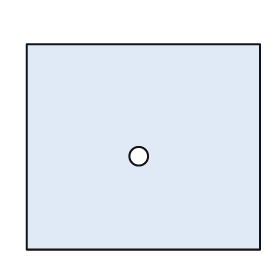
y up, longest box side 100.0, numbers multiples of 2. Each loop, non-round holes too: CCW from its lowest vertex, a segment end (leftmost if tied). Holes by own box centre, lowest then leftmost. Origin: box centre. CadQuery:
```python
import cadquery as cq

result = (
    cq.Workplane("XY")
    .moveTo(-50.0, -44.0)
    .lineTo(50.0, -44.0)
    .lineTo(50.0, 44.0)
    .lineTo(-50.0, 44.0)
    .close()
    .moveTo(-2.0, -4.0)
    .circle(4.0)
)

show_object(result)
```